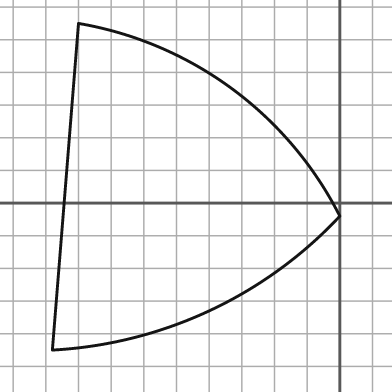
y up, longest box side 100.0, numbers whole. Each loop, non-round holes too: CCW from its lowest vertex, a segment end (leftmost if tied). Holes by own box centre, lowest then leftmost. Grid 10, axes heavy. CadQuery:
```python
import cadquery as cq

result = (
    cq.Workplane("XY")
    .moveTo(-88.0, -45.0)
    .threePointArc((-40.0, -33.0), (0.0, -4.0))
    .threePointArc((-33.0, 35.0), (-80.0, 55.0))
    .close()
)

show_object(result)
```